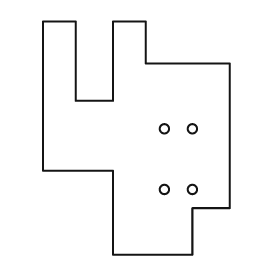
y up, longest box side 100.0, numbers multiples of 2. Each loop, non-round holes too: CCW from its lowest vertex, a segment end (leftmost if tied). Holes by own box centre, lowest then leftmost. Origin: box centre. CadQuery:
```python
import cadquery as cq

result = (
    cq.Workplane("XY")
    .moveTo(-10.0, -50.0)
    .lineTo(24.0, -50.0)
    .lineTo(24.0, -30.0)
    .lineTo(40.0, -30.0)
    .lineTo(40.0, 32.0)
    .lineTo(4.0, 32.0)
    .lineTo(4.0, 50.0)
    .lineTo(-10.0, 50.0)
    .lineTo(-10.0, 16.0)
    .lineTo(-26.0, 16.0)
    .lineTo(-26.0, 50.0)
    .lineTo(-40.0, 50.0)
    .lineTo(-40.0, -14.0)
    .lineTo(-10.0, -14.0)
    .close()
    .moveTo(12.0, -22.0)
    .circle(2.0)
    .moveTo(24.0, -22.0)
    .circle(2.0)
    .moveTo(12.0, 4.0)
    .circle(2.0)
    .moveTo(24.0, 4.0)
    .circle(2.0)
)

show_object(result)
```